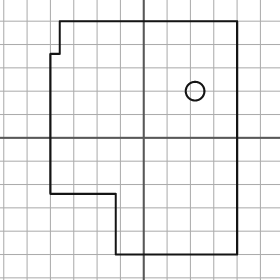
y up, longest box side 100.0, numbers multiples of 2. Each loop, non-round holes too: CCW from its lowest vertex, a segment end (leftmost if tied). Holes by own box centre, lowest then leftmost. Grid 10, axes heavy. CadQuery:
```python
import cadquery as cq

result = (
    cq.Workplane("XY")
    .moveTo(-12.0, -50.0)
    .lineTo(40.0, -50.0)
    .lineTo(40.0, 50.0)
    .lineTo(-36.0, 50.0)
    .lineTo(-36.0, 36.0)
    .lineTo(-40.0, 36.0)
    .lineTo(-40.0, -24.0)
    .lineTo(-12.0, -24.0)
    .close()
    .moveTo(22.0, 20.0)
    .circle(4.0)
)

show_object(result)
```